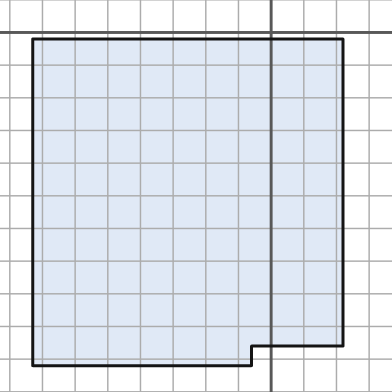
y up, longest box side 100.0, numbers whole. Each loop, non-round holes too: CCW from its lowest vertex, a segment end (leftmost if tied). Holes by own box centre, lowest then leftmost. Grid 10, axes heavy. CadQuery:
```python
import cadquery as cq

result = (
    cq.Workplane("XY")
    .moveTo(-73.0, -102.0)
    .lineTo(-6.0, -102.0)
    .lineTo(-6.0, -96.0)
    .lineTo(22.0, -96.0)
    .lineTo(22.0, -2.0)
    .lineTo(-73.0, -2.0)
    .close()
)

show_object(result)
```